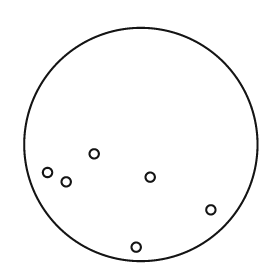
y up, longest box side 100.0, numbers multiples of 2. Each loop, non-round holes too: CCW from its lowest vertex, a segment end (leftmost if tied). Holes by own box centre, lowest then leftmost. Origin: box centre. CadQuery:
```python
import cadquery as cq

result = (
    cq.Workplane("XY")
    .moveTo(0.0, 0.0)
    .circle(50.0)
    .moveTo(-2.0, -44.0)
    .circle(2.0)
    .moveTo(30.0, -28.0)
    .circle(2.0)
    .moveTo(-32.0, -16.0)
    .circle(2.0)
    .moveTo(4.0, -14.0)
    .circle(2.0)
    .moveTo(-40.0, -12.0)
    .circle(2.0)
    .moveTo(-20.0, -4.0)
    .circle(2.0)
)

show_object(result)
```